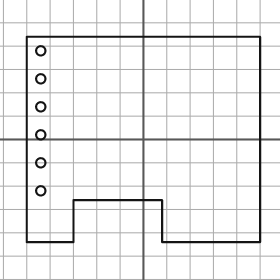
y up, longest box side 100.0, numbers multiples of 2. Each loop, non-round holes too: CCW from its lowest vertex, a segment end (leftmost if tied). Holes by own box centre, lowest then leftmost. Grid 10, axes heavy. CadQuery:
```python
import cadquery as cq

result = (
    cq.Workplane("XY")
    .moveTo(-50.0, -44.0)
    .lineTo(-30.0, -44.0)
    .lineTo(-30.0, -26.0)
    .lineTo(8.0, -26.0)
    .lineTo(8.0, -44.0)
    .lineTo(50.0, -44.0)
    .lineTo(50.0, 44.0)
    .lineTo(-50.0, 44.0)
    .close()
    .moveTo(-44.0, -22.0)
    .circle(2.0)
    .moveTo(-44.0, -10.0)
    .circle(2.0)
    .moveTo(-44.0, 2.0)
    .circle(2.0)
    .moveTo(-44.0, 14.0)
    .circle(2.0)
    .moveTo(-44.0, 26.0)
    .circle(2.0)
    .moveTo(-44.0, 38.0)
    .circle(2.0)
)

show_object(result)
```